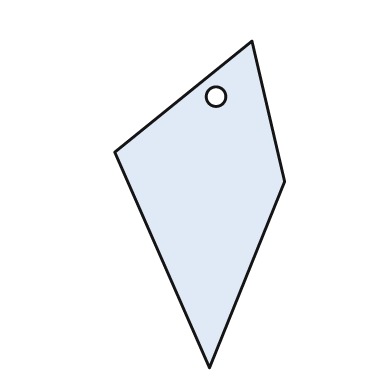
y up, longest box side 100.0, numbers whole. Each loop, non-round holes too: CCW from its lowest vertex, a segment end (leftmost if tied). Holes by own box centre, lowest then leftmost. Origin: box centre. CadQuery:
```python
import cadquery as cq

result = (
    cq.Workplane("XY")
    .moveTo(3.0, -50.0)
    .lineTo(26.0, 7.0)
    .lineTo(16.0, 50.0)
    .lineTo(-26.0, 16.0)
    .close()
    .moveTo(5.0, 33.0)
    .circle(3.0)
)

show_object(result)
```